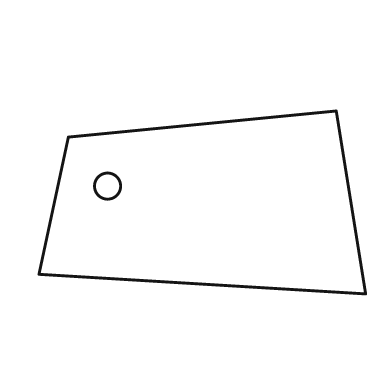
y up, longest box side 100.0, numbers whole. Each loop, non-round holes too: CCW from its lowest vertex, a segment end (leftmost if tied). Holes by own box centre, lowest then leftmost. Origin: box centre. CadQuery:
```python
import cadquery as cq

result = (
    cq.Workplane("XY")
    .moveTo(50.0, -28.0)
    .lineTo(41.0, 28.0)
    .lineTo(-41.0, 20.0)
    .lineTo(-50.0, -22.0)
    .close()
    .moveTo(-29.0, 5.0)
    .circle(4.0)
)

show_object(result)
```